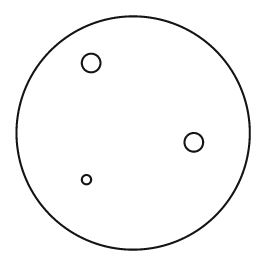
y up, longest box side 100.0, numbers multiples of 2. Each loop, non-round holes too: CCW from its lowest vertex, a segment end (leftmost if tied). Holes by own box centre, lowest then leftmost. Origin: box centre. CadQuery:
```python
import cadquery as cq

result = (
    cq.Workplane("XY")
    .moveTo(0.0, 0.0)
    .circle(50.0)
    .moveTo(-20.0, -20.0)
    .circle(2.0)
    .moveTo(26.0, -4.0)
    .circle(4.0)
    .moveTo(-18.0, 30.0)
    .circle(4.0)
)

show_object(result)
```